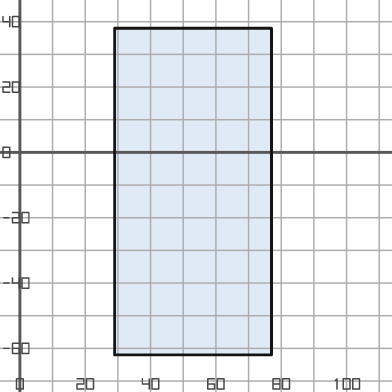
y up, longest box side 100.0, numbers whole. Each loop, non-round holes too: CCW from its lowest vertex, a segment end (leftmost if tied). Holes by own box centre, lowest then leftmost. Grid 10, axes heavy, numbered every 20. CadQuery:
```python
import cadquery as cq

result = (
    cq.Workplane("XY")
    .moveTo(29.0, -62.0)
    .lineTo(77.0, -62.0)
    .lineTo(77.0, 38.0)
    .lineTo(29.0, 38.0)
    .close()
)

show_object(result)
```